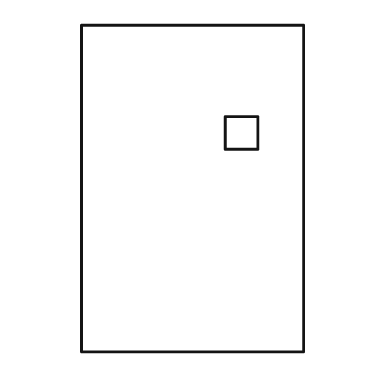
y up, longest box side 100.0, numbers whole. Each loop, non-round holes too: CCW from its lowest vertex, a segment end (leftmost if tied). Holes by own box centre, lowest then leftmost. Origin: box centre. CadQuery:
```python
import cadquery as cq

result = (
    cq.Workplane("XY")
    .moveTo(-34.0, -50.0)
    .lineTo(34.0, -50.0)
    .lineTo(34.0, 50.0)
    .lineTo(-34.0, 50.0)
    .close()
    .moveTo(10.0, 12.0)
    .lineTo(20.0, 12.0)
    .lineTo(20.0, 22.0)
    .lineTo(10.0, 22.0)
    .close()
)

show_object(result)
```